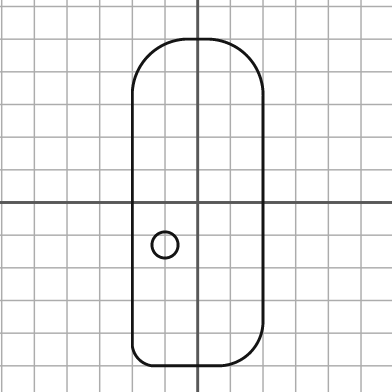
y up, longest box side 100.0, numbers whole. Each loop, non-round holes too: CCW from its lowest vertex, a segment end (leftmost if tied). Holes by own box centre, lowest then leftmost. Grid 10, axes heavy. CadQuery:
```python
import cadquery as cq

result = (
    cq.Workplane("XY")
    .moveTo(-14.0, -50.0)
    .lineTo(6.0, -50.0)
    .threePointArc((16.0, -46.0), (20.0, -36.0))
    .lineTo(20.0, 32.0)
    .threePointArc((15.0, 45.0), (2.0, 50.0))
    .lineTo(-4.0, 50.0)
    .threePointArc((-15.0, 45.0), (-20.0, 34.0))
    .lineTo(-20.0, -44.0)
    .threePointArc((-18.0, -48.0), (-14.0, -50.0))
    .close()
    .moveTo(-10.0, -13.0)
    .circle(4.0)
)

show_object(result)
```